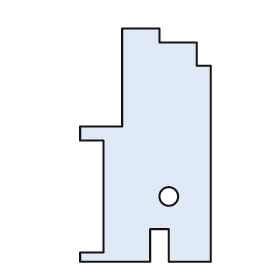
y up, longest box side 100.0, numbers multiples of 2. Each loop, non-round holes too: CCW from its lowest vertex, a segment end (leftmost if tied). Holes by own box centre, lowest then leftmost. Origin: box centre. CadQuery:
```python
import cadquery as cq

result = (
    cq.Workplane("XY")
    .moveTo(-28.0, -50.0)
    .lineTo(2.0, -50.0)
    .lineTo(2.0, -36.0)
    .lineTo(10.0, -36.0)
    .lineTo(10.0, -50.0)
    .lineTo(28.0, -50.0)
    .lineTo(28.0, 34.0)
    .lineTo(22.0, 34.0)
    .lineTo(22.0, 44.0)
    .lineTo(6.0, 44.0)
    .lineTo(6.0, 50.0)
    .lineTo(-10.0, 50.0)
    .lineTo(-10.0, 8.0)
    .lineTo(-28.0, 8.0)
    .lineTo(-28.0, 2.0)
    .lineTo(-18.0, 2.0)
    .lineTo(-18.0, -46.0)
    .lineTo(-28.0, -46.0)
    .close()
    .moveTo(10.0, -22.0)
    .circle(4.0)
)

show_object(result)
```